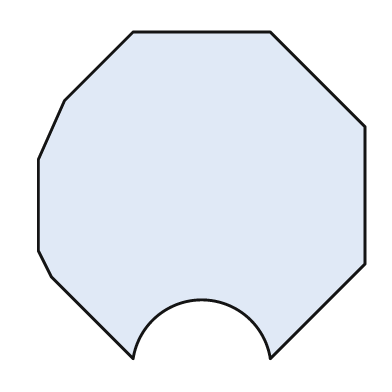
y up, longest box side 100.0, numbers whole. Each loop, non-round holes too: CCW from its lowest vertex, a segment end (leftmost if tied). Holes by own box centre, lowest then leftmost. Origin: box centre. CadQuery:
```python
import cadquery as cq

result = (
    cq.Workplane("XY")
    .moveTo(-21.0, -50.0)
    .threePointArc((0.0, -32.0), (21.0, -50.0))
    .lineTo(50.0, -21.0)
    .lineTo(50.0, 21.0)
    .lineTo(21.0, 50.0)
    .lineTo(-21.0, 50.0)
    .lineTo(-42.0, 29.0)
    .lineTo(-50.0, 11.0)
    .lineTo(-50.0, -17.0)
    .lineTo(-46.0, -25.0)
    .close()
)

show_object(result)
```